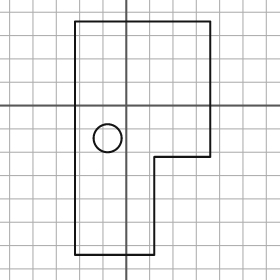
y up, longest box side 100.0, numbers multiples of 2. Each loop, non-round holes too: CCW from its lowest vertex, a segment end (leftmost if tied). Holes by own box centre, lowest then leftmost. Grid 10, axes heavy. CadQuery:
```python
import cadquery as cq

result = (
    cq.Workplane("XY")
    .moveTo(-22.0, -64.0)
    .lineTo(12.0, -64.0)
    .lineTo(12.0, -22.0)
    .lineTo(36.0, -22.0)
    .lineTo(36.0, 36.0)
    .lineTo(-22.0, 36.0)
    .close()
    .moveTo(-8.0, -14.0)
    .circle(6.0)
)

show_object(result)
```